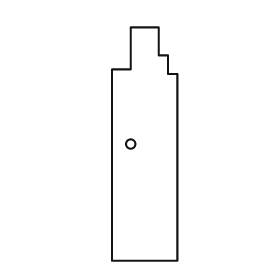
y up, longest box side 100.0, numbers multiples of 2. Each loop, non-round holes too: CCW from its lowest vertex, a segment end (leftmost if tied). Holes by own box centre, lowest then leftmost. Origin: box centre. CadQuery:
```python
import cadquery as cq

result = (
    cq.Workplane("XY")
    .moveTo(-14.0, -50.0)
    .lineTo(14.0, -50.0)
    .lineTo(14.0, 30.0)
    .lineTo(10.0, 30.0)
    .lineTo(10.0, 38.0)
    .lineTo(6.0, 38.0)
    .lineTo(6.0, 50.0)
    .lineTo(-6.0, 50.0)
    .lineTo(-6.0, 32.0)
    .lineTo(-14.0, 32.0)
    .close()
    .moveTo(-6.0, 0.0)
    .circle(2.0)
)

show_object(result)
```